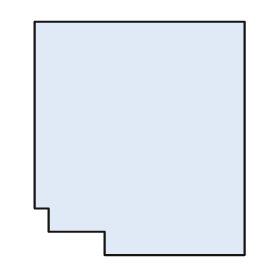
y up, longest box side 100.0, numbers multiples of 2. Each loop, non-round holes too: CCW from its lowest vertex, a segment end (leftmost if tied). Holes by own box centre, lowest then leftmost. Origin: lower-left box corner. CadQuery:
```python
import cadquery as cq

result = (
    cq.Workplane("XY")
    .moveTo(30.0, 0.0)
    .lineTo(90.0, 0.0)
    .lineTo(90.0, 100.0)
    .lineTo(0.0, 100.0)
    .lineTo(0.0, 20.0)
    .lineTo(6.0, 20.0)
    .lineTo(6.0, 10.0)
    .lineTo(30.0, 10.0)
    .close()
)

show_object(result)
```